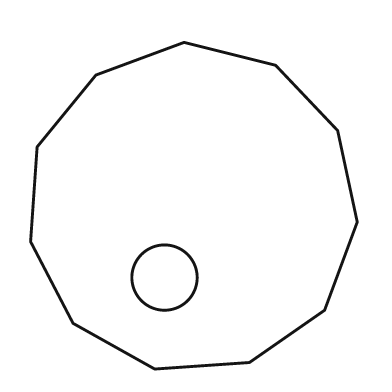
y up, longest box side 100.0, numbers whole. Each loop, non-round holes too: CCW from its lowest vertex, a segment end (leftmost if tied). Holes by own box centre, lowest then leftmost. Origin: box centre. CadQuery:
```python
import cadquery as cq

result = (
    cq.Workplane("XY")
    .moveTo(-12.0, -50.0)
    .lineTo(17.0, -48.0)
    .lineTo(40.0, -32.0)
    .lineTo(50.0, -5.0)
    .lineTo(44.0, 23.0)
    .lineTo(25.0, 43.0)
    .lineTo(-3.0, 50.0)
    .lineTo(-30.0, 40.0)
    .lineTo(-48.0, 18.0)
    .lineTo(-50.0, -11.0)
    .lineTo(-37.0, -36.0)
    .close()
    .moveTo(-9.0, -22.0)
    .circle(10.0)
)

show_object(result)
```